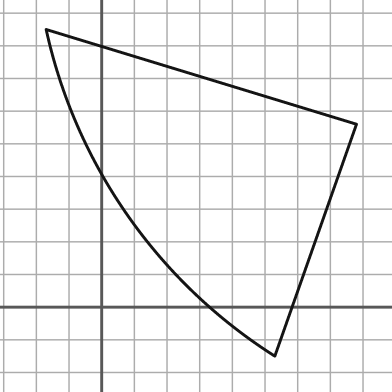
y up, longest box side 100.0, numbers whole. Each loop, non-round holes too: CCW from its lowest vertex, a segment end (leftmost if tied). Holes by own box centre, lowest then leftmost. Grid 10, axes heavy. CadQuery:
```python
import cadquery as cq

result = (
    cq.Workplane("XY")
    .moveTo(53.0, -15.0)
    .lineTo(78.0, 56.0)
    .lineTo(-17.0, 85.0)
    .threePointArc((8.0, 28.0), (53.0, -15.0))
    .close()
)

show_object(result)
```